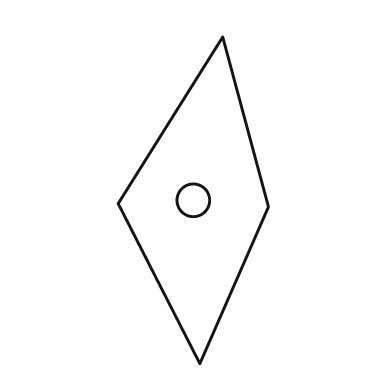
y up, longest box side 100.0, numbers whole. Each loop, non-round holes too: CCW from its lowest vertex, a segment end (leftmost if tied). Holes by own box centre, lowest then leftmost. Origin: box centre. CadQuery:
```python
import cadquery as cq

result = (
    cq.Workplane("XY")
    .moveTo(2.0, -50.0)
    .lineTo(23.0, -2.0)
    .lineTo(9.0, 50.0)
    .lineTo(-23.0, -1.0)
    .close()
    .moveTo(0.0, 0.0)
    .circle(5.0)
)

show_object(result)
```